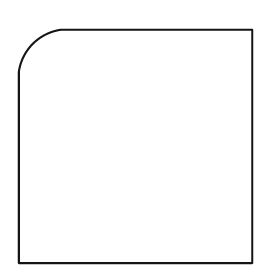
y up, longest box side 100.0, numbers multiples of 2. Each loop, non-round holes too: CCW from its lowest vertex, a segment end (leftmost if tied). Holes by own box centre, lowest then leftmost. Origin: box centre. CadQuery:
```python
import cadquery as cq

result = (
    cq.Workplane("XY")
    .moveTo(-50.0, -50.0)
    .lineTo(50.0, -50.0)
    .lineTo(50.0, 50.0)
    .lineTo(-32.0, 50.0)
    .threePointArc((-44.0, 44.0), (-50.0, 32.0))
    .close()
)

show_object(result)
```